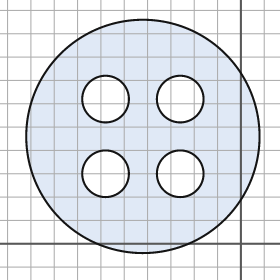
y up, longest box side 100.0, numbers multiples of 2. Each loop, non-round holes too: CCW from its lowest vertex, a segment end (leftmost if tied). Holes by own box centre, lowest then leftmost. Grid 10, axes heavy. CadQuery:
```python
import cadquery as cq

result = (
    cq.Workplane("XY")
    .moveTo(-42.0, 46.0)
    .circle(50.0)
    .moveTo(-58.0, 30.0)
    .circle(10.0)
    .moveTo(-26.0, 30.0)
    .circle(10.0)
    .moveTo(-58.0, 62.0)
    .circle(10.0)
    .moveTo(-26.0, 62.0)
    .circle(10.0)
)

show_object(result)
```